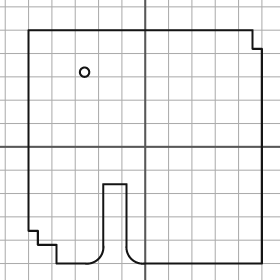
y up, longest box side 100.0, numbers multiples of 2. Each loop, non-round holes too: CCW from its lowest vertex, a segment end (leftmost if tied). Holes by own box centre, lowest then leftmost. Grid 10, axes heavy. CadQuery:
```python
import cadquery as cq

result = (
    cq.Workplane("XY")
    .moveTo(-38.0, -50.0)
    .lineTo(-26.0, -50.0)
    .threePointArc((-20.0, -48.0), (-18.0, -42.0))
    .lineTo(-18.0, -16.0)
    .lineTo(-8.0, -16.0)
    .lineTo(-8.0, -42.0)
    .threePointArc((-6.0, -48.0), (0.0, -50.0))
    .lineTo(50.0, -50.0)
    .lineTo(50.0, 42.0)
    .lineTo(46.0, 42.0)
    .lineTo(46.0, 50.0)
    .lineTo(-50.0, 50.0)
    .lineTo(-50.0, -36.0)
    .lineTo(-46.0, -36.0)
    .lineTo(-46.0, -42.0)
    .lineTo(-38.0, -42.0)
    .close()
    .moveTo(-26.0, 32.0)
    .circle(2.0)
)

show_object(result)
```